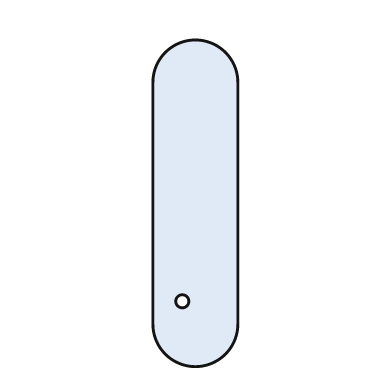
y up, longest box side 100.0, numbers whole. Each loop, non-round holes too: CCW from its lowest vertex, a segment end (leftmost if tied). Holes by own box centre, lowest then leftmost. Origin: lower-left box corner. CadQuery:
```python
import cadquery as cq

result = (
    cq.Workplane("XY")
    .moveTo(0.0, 13.0)
    .threePointArc((13.0, 0.0), (26.0, 13.0))
    .lineTo(26.0, 87.0)
    .threePointArc((13.0, 100.0), (0.0, 87.0))
    .close()
    .moveTo(9.0, 20.0)
    .circle(2.0)
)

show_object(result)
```